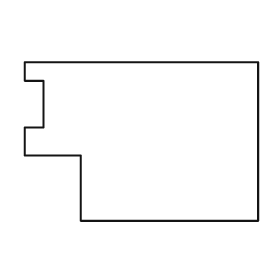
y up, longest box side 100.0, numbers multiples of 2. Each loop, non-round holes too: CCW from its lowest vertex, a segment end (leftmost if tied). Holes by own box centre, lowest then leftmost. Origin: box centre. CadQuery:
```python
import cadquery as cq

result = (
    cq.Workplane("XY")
    .moveTo(-26.0, -34.0)
    .lineTo(50.0, -34.0)
    .lineTo(50.0, 34.0)
    .lineTo(-50.0, 34.0)
    .lineTo(-50.0, 26.0)
    .lineTo(-42.0, 26.0)
    .lineTo(-42.0, 6.0)
    .lineTo(-50.0, 6.0)
    .lineTo(-50.0, -6.0)
    .lineTo(-26.0, -6.0)
    .close()
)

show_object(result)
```